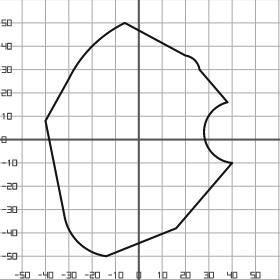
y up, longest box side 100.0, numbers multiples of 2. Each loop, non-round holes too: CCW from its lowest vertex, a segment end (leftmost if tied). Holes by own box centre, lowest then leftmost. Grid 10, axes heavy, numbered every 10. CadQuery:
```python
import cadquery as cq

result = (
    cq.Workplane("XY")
    .moveTo(-14.0, -50.0)
    .lineTo(16.0, -38.0)
    .lineTo(40.0, -10.0)
    .threePointArc((28.0, 2.0), (38.0, 16.0))
    .lineTo(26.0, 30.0)
    .threePointArc((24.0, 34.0), (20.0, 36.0))
    .lineTo(-6.0, 50.0)
    .threePointArc((-20.0, 40.0), (-30.0, 26.0))
    .lineTo(-40.0, 8.0)
    .lineTo(-32.0, -32.0)
    .threePointArc((-26.0, -44.0), (-14.0, -50.0))
    .close()
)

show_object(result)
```